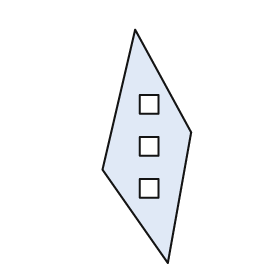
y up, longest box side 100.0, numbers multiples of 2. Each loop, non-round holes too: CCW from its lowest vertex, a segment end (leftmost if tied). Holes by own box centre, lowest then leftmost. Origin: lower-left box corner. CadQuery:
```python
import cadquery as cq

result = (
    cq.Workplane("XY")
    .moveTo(28.0, 0.0)
    .lineTo(38.0, 56.0)
    .lineTo(14.0, 100.0)
    .lineTo(0.0, 40.0)
    .close()
    .moveTo(16.0, 28.0)
    .lineTo(24.0, 28.0)
    .lineTo(24.0, 36.0)
    .lineTo(16.0, 36.0)
    .close()
    .moveTo(16.0, 46.0)
    .lineTo(24.0, 46.0)
    .lineTo(24.0, 54.0)
    .lineTo(16.0, 54.0)
    .close()
    .moveTo(16.0, 64.0)
    .lineTo(24.0, 64.0)
    .lineTo(24.0, 72.0)
    .lineTo(16.0, 72.0)
    .close()
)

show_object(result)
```